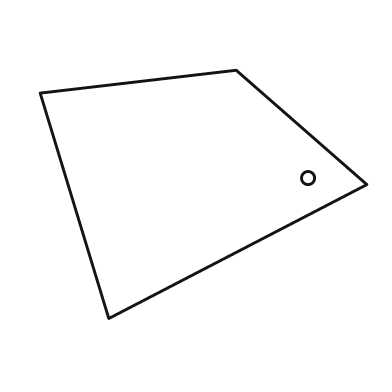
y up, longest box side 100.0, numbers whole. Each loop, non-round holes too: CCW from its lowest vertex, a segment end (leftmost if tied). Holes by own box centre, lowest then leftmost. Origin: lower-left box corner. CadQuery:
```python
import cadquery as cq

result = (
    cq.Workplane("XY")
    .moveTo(21.0, 0.0)
    .lineTo(100.0, 41.0)
    .lineTo(60.0, 76.0)
    .lineTo(0.0, 69.0)
    .close()
    .moveTo(82.0, 43.0)
    .circle(2.0)
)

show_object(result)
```